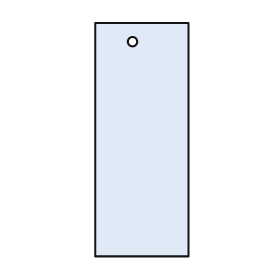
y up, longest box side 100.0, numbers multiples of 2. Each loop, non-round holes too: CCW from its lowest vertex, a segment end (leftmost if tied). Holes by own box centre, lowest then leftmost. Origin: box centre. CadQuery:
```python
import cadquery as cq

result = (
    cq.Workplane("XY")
    .moveTo(-20.0, -50.0)
    .lineTo(20.0, -50.0)
    .lineTo(20.0, 50.0)
    .lineTo(-20.0, 50.0)
    .close()
    .moveTo(-4.0, 42.0)
    .circle(2.0)
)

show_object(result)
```